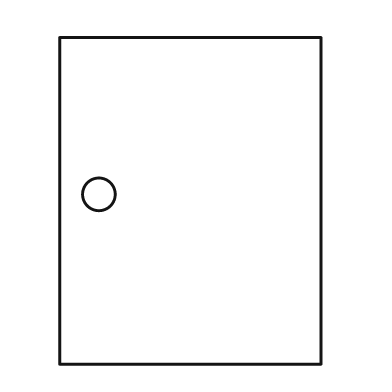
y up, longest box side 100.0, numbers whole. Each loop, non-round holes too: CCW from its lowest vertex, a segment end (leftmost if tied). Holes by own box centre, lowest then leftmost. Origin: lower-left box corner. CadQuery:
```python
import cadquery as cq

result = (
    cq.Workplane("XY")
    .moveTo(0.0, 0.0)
    .lineTo(80.0, 0.0)
    .lineTo(80.0, 100.0)
    .lineTo(0.0, 100.0)
    .close()
    .moveTo(12.0, 52.0)
    .circle(5.0)
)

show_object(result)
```